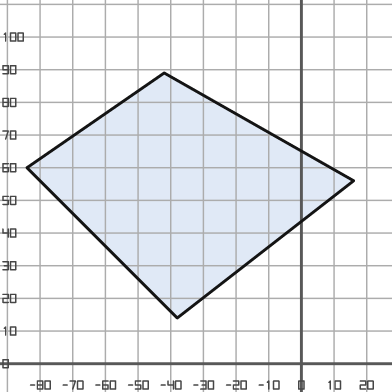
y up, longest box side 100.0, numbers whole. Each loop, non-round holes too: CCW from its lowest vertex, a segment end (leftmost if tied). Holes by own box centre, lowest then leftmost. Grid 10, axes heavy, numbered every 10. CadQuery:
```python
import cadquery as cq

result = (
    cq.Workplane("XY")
    .moveTo(-38.0, 14.0)
    .lineTo(16.0, 56.0)
    .lineTo(-42.0, 89.0)
    .lineTo(-84.0, 60.0)
    .close()
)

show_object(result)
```